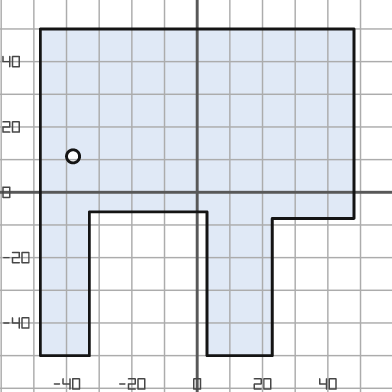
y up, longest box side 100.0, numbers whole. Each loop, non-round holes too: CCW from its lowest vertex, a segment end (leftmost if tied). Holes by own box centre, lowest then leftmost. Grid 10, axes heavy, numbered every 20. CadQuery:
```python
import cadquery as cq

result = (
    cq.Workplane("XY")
    .moveTo(-48.0, -50.0)
    .lineTo(-33.0, -50.0)
    .lineTo(-33.0, -6.0)
    .lineTo(3.0, -6.0)
    .lineTo(3.0, -50.0)
    .lineTo(23.0, -50.0)
    .lineTo(23.0, -8.0)
    .lineTo(48.0, -8.0)
    .lineTo(48.0, 50.0)
    .lineTo(-48.0, 50.0)
    .close()
    .moveTo(-38.0, 11.0)
    .circle(2.0)
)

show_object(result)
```